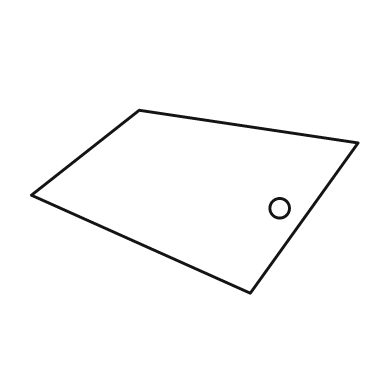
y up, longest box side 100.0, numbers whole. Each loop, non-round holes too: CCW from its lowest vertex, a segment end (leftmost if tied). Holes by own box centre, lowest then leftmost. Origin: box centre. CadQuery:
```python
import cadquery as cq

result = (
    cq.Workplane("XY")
    .moveTo(17.0, -28.0)
    .lineTo(50.0, 18.0)
    .lineTo(-17.0, 28.0)
    .lineTo(-50.0, 2.0)
    .close()
    .moveTo(26.0, -2.0)
    .circle(3.0)
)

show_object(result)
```